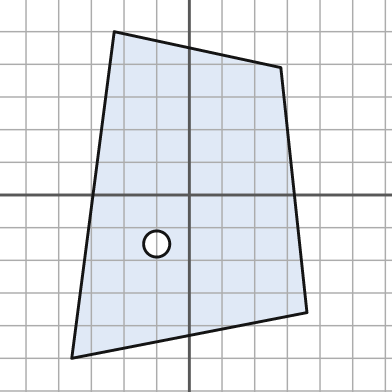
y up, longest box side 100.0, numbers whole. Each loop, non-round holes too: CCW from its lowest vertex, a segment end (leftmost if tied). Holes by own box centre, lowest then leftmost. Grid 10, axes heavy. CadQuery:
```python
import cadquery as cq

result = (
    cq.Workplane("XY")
    .moveTo(-36.0, -50.0)
    .lineTo(36.0, -36.0)
    .lineTo(28.0, 39.0)
    .lineTo(-23.0, 50.0)
    .close()
    .moveTo(-10.0, -15.0)
    .circle(4.0)
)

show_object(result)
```